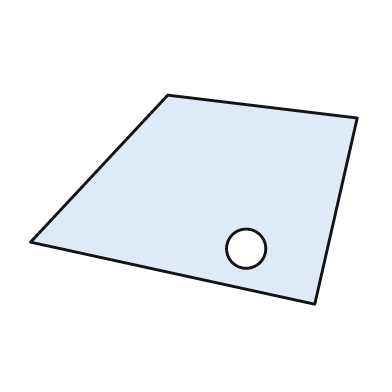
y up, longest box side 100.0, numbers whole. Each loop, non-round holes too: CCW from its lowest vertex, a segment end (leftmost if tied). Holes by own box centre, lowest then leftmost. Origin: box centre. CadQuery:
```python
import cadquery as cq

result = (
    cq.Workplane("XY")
    .moveTo(37.0, -32.0)
    .lineTo(50.0, 25.0)
    .lineTo(-8.0, 32.0)
    .lineTo(-50.0, -13.0)
    .close()
    .moveTo(16.0, -15.0)
    .circle(6.0)
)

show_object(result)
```